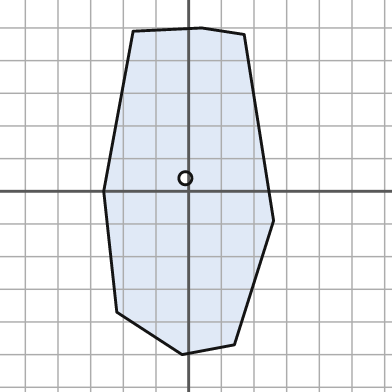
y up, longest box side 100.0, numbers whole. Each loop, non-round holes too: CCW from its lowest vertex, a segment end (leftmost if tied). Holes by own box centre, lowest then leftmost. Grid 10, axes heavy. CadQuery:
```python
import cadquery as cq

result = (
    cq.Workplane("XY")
    .moveTo(-2.0, -50.0)
    .lineTo(14.0, -47.0)
    .lineTo(26.0, -9.0)
    .lineTo(17.0, 48.0)
    .lineTo(4.0, 50.0)
    .lineTo(-17.0, 49.0)
    .lineTo(-26.0, 0.0)
    .lineTo(-22.0, -37.0)
    .close()
    .moveTo(-1.0, 4.0)
    .circle(2.0)
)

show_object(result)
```